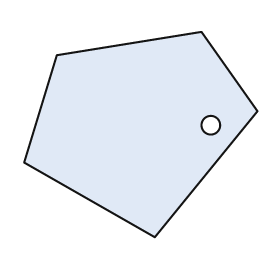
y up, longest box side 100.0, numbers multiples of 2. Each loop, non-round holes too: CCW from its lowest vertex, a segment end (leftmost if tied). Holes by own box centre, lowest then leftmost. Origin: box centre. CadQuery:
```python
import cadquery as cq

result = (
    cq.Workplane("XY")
    .moveTo(6.0, -44.0)
    .lineTo(50.0, 10.0)
    .lineTo(26.0, 44.0)
    .lineTo(-36.0, 34.0)
    .lineTo(-50.0, -12.0)
    .close()
    .moveTo(30.0, 4.0)
    .circle(4.0)
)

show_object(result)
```